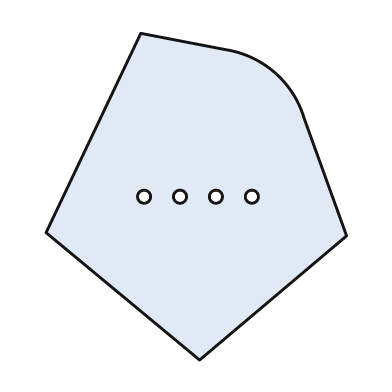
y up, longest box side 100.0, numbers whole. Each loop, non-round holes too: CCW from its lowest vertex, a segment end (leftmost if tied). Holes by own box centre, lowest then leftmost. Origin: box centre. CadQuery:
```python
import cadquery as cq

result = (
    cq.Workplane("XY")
    .moveTo(1.0, -50.0)
    .lineTo(46.0, -12.0)
    .lineTo(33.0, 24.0)
    .threePointArc((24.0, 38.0), (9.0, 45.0))
    .lineTo(-17.0, 50.0)
    .lineTo(-46.0, -11.0)
    .close()
    .moveTo(-16.0, 0.0)
    .circle(2.0)
    .moveTo(-5.0, 0.0)
    .circle(2.0)
    .moveTo(6.0, 0.0)
    .circle(2.0)
    .moveTo(17.0, 0.0)
    .circle(2.0)
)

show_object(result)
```